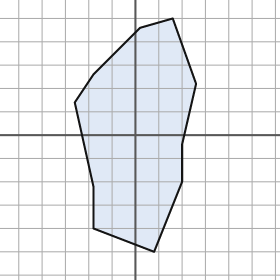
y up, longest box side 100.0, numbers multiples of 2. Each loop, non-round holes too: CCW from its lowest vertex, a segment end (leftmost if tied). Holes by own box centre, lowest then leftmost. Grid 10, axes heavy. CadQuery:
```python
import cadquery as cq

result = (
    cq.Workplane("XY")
    .moveTo(8.0, -50.0)
    .lineTo(20.0, -20.0)
    .lineTo(20.0, -4.0)
    .lineTo(26.0, 22.0)
    .lineTo(16.0, 50.0)
    .lineTo(2.0, 46.0)
    .lineTo(-18.0, 26.0)
    .lineTo(-26.0, 14.0)
    .lineTo(-18.0, -22.0)
    .lineTo(-18.0, -40.0)
    .close()
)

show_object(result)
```